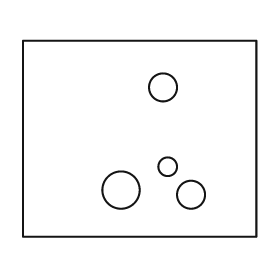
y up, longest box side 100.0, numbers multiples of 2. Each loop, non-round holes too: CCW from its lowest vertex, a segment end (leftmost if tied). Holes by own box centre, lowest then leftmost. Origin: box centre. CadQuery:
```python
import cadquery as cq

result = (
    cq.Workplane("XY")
    .moveTo(-50.0, -42.0)
    .lineTo(50.0, -42.0)
    .lineTo(50.0, 42.0)
    .lineTo(-50.0, 42.0)
    .close()
    .moveTo(22.0, -24.0)
    .circle(6.0)
    .moveTo(-8.0, -22.0)
    .circle(8.0)
    .moveTo(12.0, -12.0)
    .circle(4.0)
    .moveTo(10.0, 22.0)
    .circle(6.0)
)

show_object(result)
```